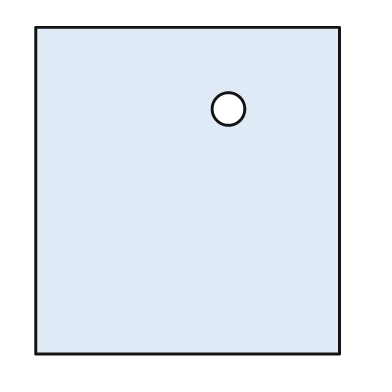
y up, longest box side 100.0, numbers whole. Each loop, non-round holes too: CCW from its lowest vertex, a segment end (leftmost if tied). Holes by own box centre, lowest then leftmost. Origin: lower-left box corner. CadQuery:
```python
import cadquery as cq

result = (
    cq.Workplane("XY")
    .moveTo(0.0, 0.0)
    .lineTo(93.0, 0.0)
    .lineTo(93.0, 100.0)
    .lineTo(0.0, 100.0)
    .close()
    .moveTo(59.0, 75.0)
    .circle(5.0)
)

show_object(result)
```